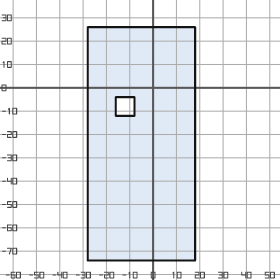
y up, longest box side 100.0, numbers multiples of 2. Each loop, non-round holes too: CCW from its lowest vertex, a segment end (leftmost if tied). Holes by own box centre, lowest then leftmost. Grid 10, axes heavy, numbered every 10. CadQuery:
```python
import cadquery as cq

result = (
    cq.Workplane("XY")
    .moveTo(-28.0, -74.0)
    .lineTo(18.0, -74.0)
    .lineTo(18.0, 26.0)
    .lineTo(-28.0, 26.0)
    .close()
    .moveTo(-16.0, -12.0)
    .lineTo(-8.0, -12.0)
    .lineTo(-8.0, -4.0)
    .lineTo(-16.0, -4.0)
    .close()
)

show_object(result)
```